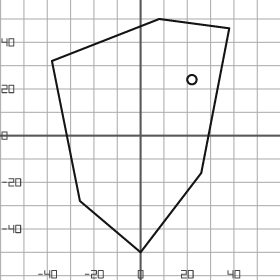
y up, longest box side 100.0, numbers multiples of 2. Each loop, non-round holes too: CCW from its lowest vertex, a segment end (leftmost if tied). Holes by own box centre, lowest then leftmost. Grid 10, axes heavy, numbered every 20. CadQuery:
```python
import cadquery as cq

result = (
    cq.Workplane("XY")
    .moveTo(0.0, -50.0)
    .lineTo(26.0, -16.0)
    .lineTo(38.0, 46.0)
    .lineTo(8.0, 50.0)
    .lineTo(-38.0, 32.0)
    .lineTo(-26.0, -28.0)
    .close()
    .moveTo(22.0, 24.0)
    .circle(2.0)
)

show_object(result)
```